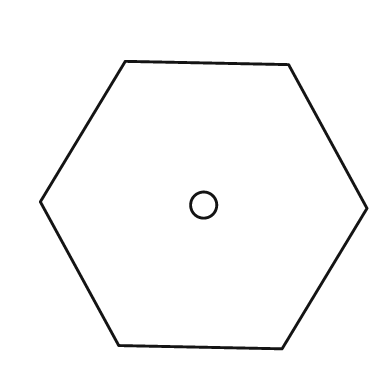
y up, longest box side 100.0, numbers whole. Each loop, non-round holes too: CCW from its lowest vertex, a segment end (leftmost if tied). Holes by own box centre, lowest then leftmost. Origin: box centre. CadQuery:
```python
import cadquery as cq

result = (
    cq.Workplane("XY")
    .moveTo(24.0, -44.0)
    .lineTo(50.0, -1.0)
    .lineTo(26.0, 43.0)
    .lineTo(-24.0, 44.0)
    .lineTo(-50.0, 1.0)
    .lineTo(-26.0, -43.0)
    .close()
    .moveTo(0.0, 0.0)
    .circle(4.0)
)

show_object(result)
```